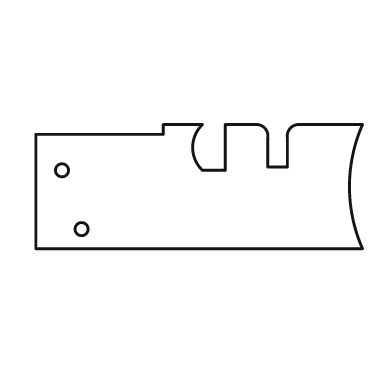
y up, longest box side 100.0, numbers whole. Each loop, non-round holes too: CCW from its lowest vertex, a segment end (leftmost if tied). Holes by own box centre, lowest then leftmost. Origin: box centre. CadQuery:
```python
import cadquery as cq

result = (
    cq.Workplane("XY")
    .moveTo(-50.0, -19.0)
    .lineTo(50.0, -19.0)
    .threePointArc((46.0, 0.0), (50.0, 19.0))
    .lineTo(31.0, 19.0)
    .threePointArc((28.0, 18.0), (27.0, 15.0))
    .lineTo(27.0, 6.0)
    .lineTo(21.0, 6.0)
    .lineTo(21.0, 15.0)
    .threePointArc((20.0, 18.0), (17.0, 19.0))
    .lineTo(8.0, 19.0)
    .lineTo(8.0, 5.0)
    .lineTo(1.0, 5.0)
    .threePointArc((-2.0, 12.0), (1.0, 19.0))
    .lineTo(-11.0, 19.0)
    .lineTo(-11.0, 16.0)
    .lineTo(-50.0, 16.0)
    .close()
    .moveTo(-36.0, -13.0)
    .circle(2.0)
    .moveTo(-42.0, 5.0)
    .circle(2.0)
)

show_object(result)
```